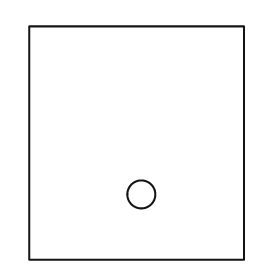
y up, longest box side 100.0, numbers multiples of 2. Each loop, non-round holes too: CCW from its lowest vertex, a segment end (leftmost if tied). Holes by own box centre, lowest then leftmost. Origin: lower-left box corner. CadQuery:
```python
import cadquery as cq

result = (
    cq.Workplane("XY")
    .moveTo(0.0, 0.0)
    .lineTo(92.0, 0.0)
    .lineTo(92.0, 100.0)
    .lineTo(0.0, 100.0)
    .close()
    .moveTo(48.0, 28.0)
    .circle(6.0)
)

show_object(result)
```